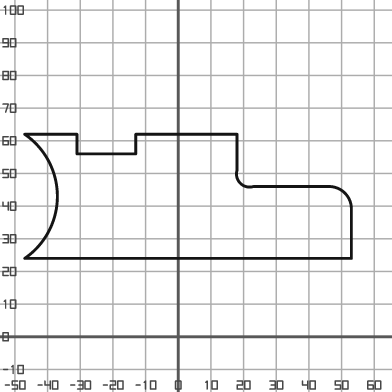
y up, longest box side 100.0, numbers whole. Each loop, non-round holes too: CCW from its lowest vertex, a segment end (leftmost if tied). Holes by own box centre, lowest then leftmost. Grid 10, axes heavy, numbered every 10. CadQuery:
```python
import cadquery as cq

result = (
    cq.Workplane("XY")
    .moveTo(-47.0, 24.0)
    .lineTo(53.0, 24.0)
    .lineTo(53.0, 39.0)
    .threePointArc((51.0, 44.0), (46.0, 46.0))
    .lineTo(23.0, 46.0)
    .threePointArc((19.0, 47.0), (18.0, 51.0))
    .lineTo(18.0, 62.0)
    .lineTo(-13.0, 62.0)
    .lineTo(-13.0, 56.0)
    .lineTo(-31.0, 56.0)
    .lineTo(-31.0, 62.0)
    .lineTo(-47.0, 62.0)
    .threePointArc((-37.0, 43.0), (-47.0, 24.0))
    .close()
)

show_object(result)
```